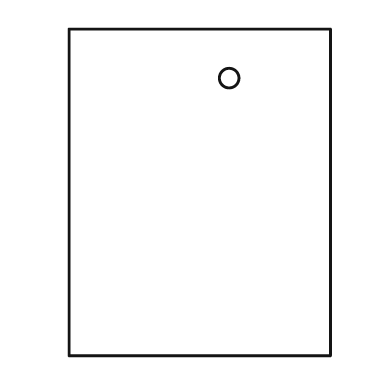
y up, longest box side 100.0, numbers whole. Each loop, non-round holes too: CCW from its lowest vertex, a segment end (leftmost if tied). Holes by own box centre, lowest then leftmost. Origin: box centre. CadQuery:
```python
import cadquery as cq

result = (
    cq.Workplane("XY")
    .moveTo(-40.0, -50.0)
    .lineTo(40.0, -50.0)
    .lineTo(40.0, 50.0)
    .lineTo(-40.0, 50.0)
    .close()
    .moveTo(9.0, 35.0)
    .circle(3.0)
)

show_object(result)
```